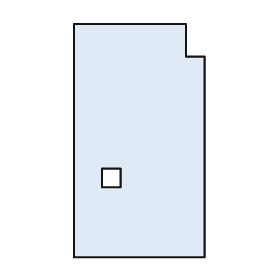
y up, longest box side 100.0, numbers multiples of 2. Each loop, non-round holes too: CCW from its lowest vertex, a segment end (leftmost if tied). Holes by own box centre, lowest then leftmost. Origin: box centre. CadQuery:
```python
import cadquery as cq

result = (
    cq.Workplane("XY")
    .moveTo(-28.0, -50.0)
    .lineTo(28.0, -50.0)
    .lineTo(28.0, 36.0)
    .lineTo(20.0, 36.0)
    .lineTo(20.0, 50.0)
    .lineTo(-28.0, 50.0)
    .close()
    .moveTo(-16.0, -20.0)
    .lineTo(-8.0, -20.0)
    .lineTo(-8.0, -12.0)
    .lineTo(-16.0, -12.0)
    .close()
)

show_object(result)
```